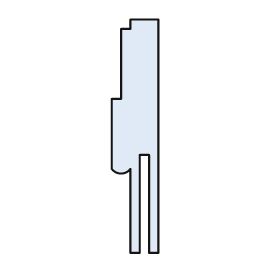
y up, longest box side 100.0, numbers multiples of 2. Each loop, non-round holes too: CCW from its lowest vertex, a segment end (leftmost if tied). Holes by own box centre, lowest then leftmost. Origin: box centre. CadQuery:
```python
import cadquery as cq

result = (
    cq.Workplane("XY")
    .moveTo(-2.0, -50.0)
    .lineTo(2.0, -50.0)
    .lineTo(2.0, -8.0)
    .lineTo(6.0, -8.0)
    .lineTo(6.0, -50.0)
    .lineTo(10.0, -50.0)
    .lineTo(10.0, 50.0)
    .lineTo(-2.0, 50.0)
    .lineTo(-2.0, 46.0)
    .lineTo(-6.0, 46.0)
    .lineTo(-6.0, 16.0)
    .lineTo(-10.0, 16.0)
    .lineTo(-10.0, -14.0)
    .threePointArc((-6.0, -16.0), (-2.0, -14.0))
    .close()
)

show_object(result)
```